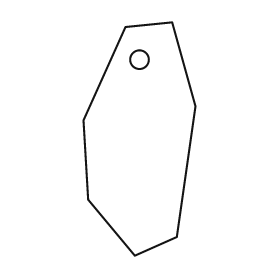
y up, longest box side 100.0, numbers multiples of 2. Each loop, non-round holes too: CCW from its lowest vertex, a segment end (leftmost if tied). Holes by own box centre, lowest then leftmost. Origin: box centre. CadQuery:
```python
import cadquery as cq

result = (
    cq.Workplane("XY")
    .moveTo(-2.0, -50.0)
    .lineTo(16.0, -42.0)
    .lineTo(24.0, 14.0)
    .lineTo(14.0, 50.0)
    .lineTo(-6.0, 48.0)
    .lineTo(-24.0, 8.0)
    .lineTo(-22.0, -26.0)
    .close()
    .moveTo(0.0, 34.0)
    .circle(4.0)
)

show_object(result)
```